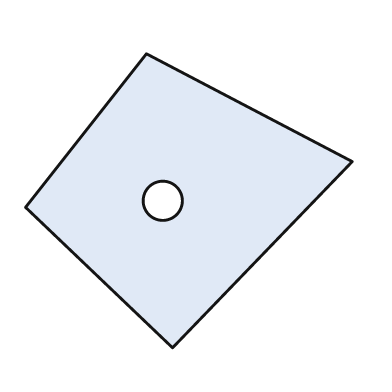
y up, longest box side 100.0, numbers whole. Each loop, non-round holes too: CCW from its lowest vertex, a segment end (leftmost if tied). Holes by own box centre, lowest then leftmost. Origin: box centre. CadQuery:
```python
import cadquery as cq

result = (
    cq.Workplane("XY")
    .moveTo(-5.0, -45.0)
    .lineTo(50.0, 12.0)
    .lineTo(-13.0, 45.0)
    .lineTo(-50.0, -2.0)
    .close()
    .moveTo(-8.0, 0.0)
    .circle(6.0)
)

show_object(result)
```